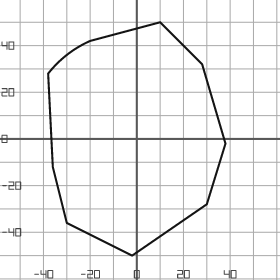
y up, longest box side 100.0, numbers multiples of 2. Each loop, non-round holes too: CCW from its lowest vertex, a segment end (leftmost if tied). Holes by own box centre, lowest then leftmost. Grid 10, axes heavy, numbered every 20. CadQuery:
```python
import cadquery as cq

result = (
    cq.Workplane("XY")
    .moveTo(-2.0, -50.0)
    .lineTo(30.0, -28.0)
    .lineTo(38.0, -2.0)
    .lineTo(28.0, 32.0)
    .lineTo(10.0, 50.0)
    .lineTo(-20.0, 42.0)
    .threePointArc((-30.0, 36.0), (-38.0, 28.0))
    .lineTo(-36.0, -12.0)
    .lineTo(-30.0, -36.0)
    .close()
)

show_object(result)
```